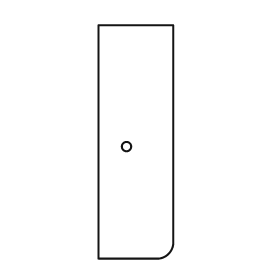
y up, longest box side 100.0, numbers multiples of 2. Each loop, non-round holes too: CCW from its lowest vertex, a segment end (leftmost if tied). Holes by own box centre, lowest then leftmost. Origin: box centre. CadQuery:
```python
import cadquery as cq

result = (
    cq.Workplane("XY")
    .moveTo(-16.0, -50.0)
    .lineTo(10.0, -50.0)
    .threePointArc((14.0, -48.0), (16.0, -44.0))
    .lineTo(16.0, 50.0)
    .lineTo(-16.0, 50.0)
    .close()
    .moveTo(-4.0, -2.0)
    .circle(2.0)
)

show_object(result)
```